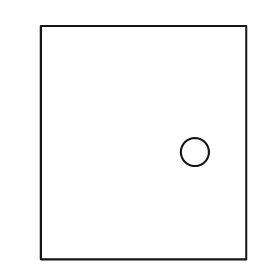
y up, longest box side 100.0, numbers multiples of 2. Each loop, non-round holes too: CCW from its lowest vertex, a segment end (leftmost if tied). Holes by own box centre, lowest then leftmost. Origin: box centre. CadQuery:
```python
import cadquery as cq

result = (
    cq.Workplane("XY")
    .moveTo(-44.0, -50.0)
    .lineTo(44.0, -50.0)
    .lineTo(44.0, 50.0)
    .lineTo(-44.0, 50.0)
    .close()
    .moveTo(22.0, -4.0)
    .circle(6.0)
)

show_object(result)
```